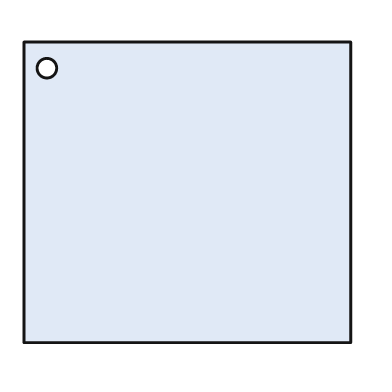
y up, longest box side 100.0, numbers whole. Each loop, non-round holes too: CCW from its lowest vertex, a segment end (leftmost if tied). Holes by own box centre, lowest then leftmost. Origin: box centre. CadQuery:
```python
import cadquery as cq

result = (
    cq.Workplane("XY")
    .moveTo(-50.0, -46.0)
    .lineTo(50.0, -46.0)
    .lineTo(50.0, 46.0)
    .lineTo(-50.0, 46.0)
    .close()
    .moveTo(-43.0, 38.0)
    .circle(3.0)
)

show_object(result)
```